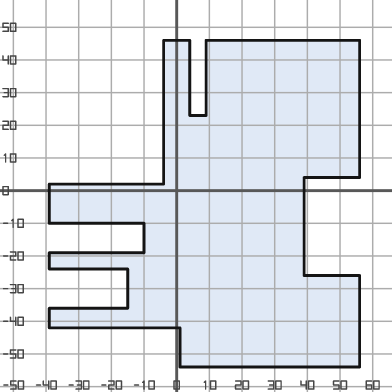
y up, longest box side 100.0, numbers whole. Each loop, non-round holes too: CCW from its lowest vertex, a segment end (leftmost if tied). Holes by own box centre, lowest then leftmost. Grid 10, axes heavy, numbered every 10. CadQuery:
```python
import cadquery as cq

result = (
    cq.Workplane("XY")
    .moveTo(1.0, -54.0)
    .lineTo(56.0, -54.0)
    .lineTo(56.0, -26.0)
    .lineTo(39.0, -26.0)
    .lineTo(39.0, 4.0)
    .lineTo(56.0, 4.0)
    .lineTo(56.0, 46.0)
    .lineTo(9.0, 46.0)
    .lineTo(9.0, 23.0)
    .lineTo(4.0, 23.0)
    .lineTo(4.0, 46.0)
    .lineTo(-4.0, 46.0)
    .lineTo(-4.0, 2.0)
    .lineTo(-39.0, 2.0)
    .lineTo(-39.0, -10.0)
    .lineTo(-10.0, -10.0)
    .lineTo(-10.0, -19.0)
    .lineTo(-39.0, -19.0)
    .lineTo(-39.0, -24.0)
    .lineTo(-15.0, -24.0)
    .lineTo(-15.0, -36.0)
    .lineTo(-39.0, -36.0)
    .lineTo(-39.0, -42.0)
    .lineTo(1.0, -42.0)
    .close()
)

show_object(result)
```